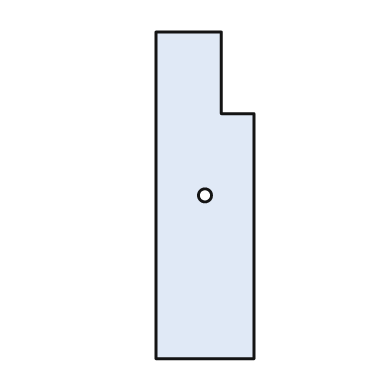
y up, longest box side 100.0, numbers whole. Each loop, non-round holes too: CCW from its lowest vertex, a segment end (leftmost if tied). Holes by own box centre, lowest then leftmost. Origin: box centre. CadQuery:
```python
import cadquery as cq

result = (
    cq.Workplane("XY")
    .moveTo(-15.0, -50.0)
    .lineTo(15.0, -50.0)
    .lineTo(15.0, 25.0)
    .lineTo(5.0, 25.0)
    .lineTo(5.0, 50.0)
    .lineTo(-15.0, 50.0)
    .close()
    .moveTo(0.0, 0.0)
    .circle(2.0)
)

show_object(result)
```